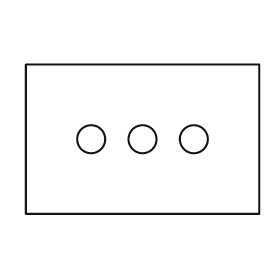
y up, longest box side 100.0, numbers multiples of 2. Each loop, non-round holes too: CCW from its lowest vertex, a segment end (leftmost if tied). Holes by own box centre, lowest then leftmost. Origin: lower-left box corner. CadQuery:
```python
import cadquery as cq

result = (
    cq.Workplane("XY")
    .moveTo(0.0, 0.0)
    .lineTo(100.0, 0.0)
    .lineTo(100.0, 64.0)
    .lineTo(0.0, 64.0)
    .close()
    .moveTo(28.0, 32.0)
    .circle(6.0)
    .moveTo(50.0, 32.0)
    .circle(6.0)
    .moveTo(72.0, 32.0)
    .circle(6.0)
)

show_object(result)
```